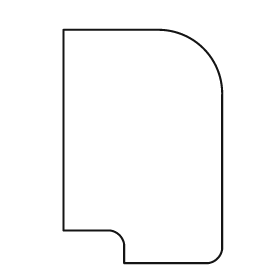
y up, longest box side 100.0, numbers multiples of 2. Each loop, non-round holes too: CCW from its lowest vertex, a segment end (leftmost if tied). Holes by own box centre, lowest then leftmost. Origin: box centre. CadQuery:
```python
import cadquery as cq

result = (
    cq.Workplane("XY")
    .moveTo(-8.0, -50.0)
    .lineTo(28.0, -50.0)
    .threePointArc((32.0, -48.0), (34.0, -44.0))
    .lineTo(34.0, 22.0)
    .threePointArc((26.0, 42.0), (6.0, 50.0))
    .lineTo(-34.0, 50.0)
    .lineTo(-34.0, -36.0)
    .lineTo(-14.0, -36.0)
    .threePointArc((-10.0, -38.0), (-8.0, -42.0))
    .close()
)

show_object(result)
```